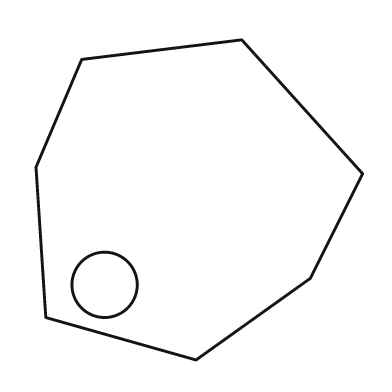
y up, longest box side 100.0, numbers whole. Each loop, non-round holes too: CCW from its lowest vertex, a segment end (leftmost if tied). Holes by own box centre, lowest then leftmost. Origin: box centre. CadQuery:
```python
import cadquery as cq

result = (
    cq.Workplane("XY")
    .moveTo(-1.0, -49.0)
    .lineTo(34.0, -24.0)
    .lineTo(50.0, 8.0)
    .lineTo(13.0, 49.0)
    .lineTo(-36.0, 43.0)
    .lineTo(-50.0, 10.0)
    .lineTo(-47.0, -36.0)
    .close()
    .moveTo(-29.0, -26.0)
    .circle(10.0)
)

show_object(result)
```